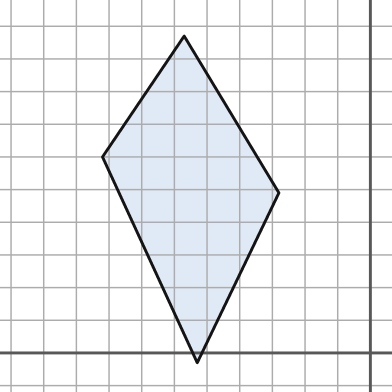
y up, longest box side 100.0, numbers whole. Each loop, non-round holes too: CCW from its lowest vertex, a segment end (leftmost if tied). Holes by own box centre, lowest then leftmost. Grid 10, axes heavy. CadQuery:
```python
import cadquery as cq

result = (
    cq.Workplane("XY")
    .moveTo(-53.0, -3.0)
    .lineTo(-28.0, 49.0)
    .lineTo(-57.0, 97.0)
    .lineTo(-82.0, 60.0)
    .close()
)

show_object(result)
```